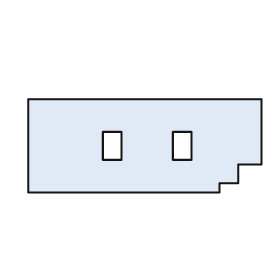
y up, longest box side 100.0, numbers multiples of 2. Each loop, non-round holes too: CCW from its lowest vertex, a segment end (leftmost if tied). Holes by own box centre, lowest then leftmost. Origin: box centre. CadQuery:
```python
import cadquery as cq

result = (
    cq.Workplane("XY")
    .moveTo(-50.0, -20.0)
    .lineTo(32.0, -20.0)
    .lineTo(32.0, -16.0)
    .lineTo(40.0, -16.0)
    .lineTo(40.0, -8.0)
    .lineTo(50.0, -8.0)
    .lineTo(50.0, 20.0)
    .lineTo(-50.0, 20.0)
    .close()
    .moveTo(-18.0, -6.0)
    .lineTo(-10.0, -6.0)
    .lineTo(-10.0, 6.0)
    .lineTo(-18.0, 6.0)
    .close()
    .moveTo(12.0, -6.0)
    .lineTo(20.0, -6.0)
    .lineTo(20.0, 6.0)
    .lineTo(12.0, 6.0)
    .close()
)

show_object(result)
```